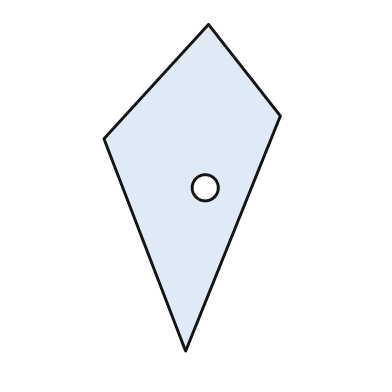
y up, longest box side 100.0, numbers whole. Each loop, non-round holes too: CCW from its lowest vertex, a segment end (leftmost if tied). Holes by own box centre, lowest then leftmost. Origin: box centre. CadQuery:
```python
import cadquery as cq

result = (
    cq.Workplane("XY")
    .moveTo(-2.0, -50.0)
    .lineTo(27.0, 22.0)
    .lineTo(5.0, 50.0)
    .lineTo(-27.0, 15.0)
    .close()
    .moveTo(4.0, 0.0)
    .circle(4.0)
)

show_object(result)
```